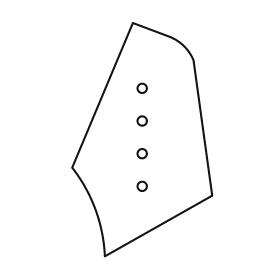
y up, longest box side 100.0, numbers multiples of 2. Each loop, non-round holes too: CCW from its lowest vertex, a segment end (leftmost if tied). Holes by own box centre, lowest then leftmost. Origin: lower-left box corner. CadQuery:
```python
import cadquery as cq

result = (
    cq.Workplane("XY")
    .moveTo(14.0, 0.0)
    .lineTo(60.0, 26.0)
    .lineTo(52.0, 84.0)
    .threePointArc((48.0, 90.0), (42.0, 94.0))
    .lineTo(26.0, 100.0)
    .lineTo(0.0, 38.0)
    .threePointArc((10.0, 20.0), (14.0, 0.0))
    .close()
    .moveTo(30.0, 30.0)
    .circle(2.0)
    .moveTo(30.0, 44.0)
    .circle(2.0)
    .moveTo(30.0, 58.0)
    .circle(2.0)
    .moveTo(30.0, 72.0)
    .circle(2.0)
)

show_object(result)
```